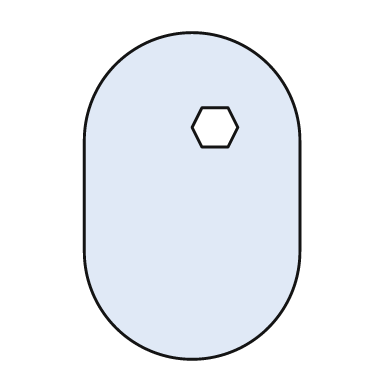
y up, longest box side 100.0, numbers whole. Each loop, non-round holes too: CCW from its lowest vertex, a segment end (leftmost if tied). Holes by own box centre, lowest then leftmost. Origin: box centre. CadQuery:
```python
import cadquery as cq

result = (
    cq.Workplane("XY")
    .moveTo(-33.0, -17.0)
    .threePointArc((0.0, -50.0), (33.0, -17.0))
    .lineTo(33.0, 17.0)
    .threePointArc((0.0, 50.0), (-33.0, 17.0))
    .close()
    .moveTo(3.0, 15.0)
    .lineTo(11.0, 15.0)
    .lineTo(14.0, 21.0)
    .lineTo(11.0, 27.0)
    .lineTo(3.0, 27.0)
    .lineTo(0.0, 21.0)
    .close()
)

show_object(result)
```